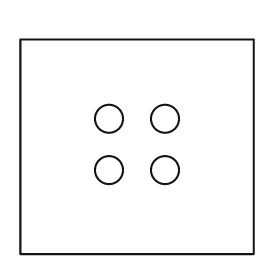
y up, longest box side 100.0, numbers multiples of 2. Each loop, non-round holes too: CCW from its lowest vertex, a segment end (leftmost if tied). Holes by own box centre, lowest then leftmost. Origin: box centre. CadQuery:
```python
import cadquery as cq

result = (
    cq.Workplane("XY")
    .moveTo(-50.0, -46.0)
    .lineTo(50.0, -46.0)
    .lineTo(50.0, 46.0)
    .lineTo(-50.0, 46.0)
    .close()
    .moveTo(-12.0, -10.0)
    .circle(6.0)
    .moveTo(12.0, -10.0)
    .circle(6.0)
    .moveTo(-12.0, 12.0)
    .circle(6.0)
    .moveTo(12.0, 12.0)
    .circle(6.0)
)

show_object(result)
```